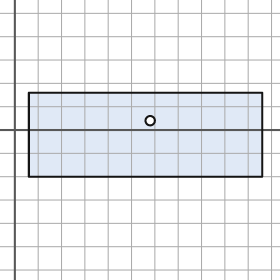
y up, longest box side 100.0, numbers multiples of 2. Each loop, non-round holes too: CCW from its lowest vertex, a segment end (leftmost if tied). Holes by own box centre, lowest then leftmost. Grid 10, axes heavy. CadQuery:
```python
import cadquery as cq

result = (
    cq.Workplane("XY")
    .moveTo(6.0, -20.0)
    .lineTo(106.0, -20.0)
    .lineTo(106.0, 16.0)
    .lineTo(6.0, 16.0)
    .close()
    .moveTo(58.0, 4.0)
    .circle(2.0)
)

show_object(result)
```